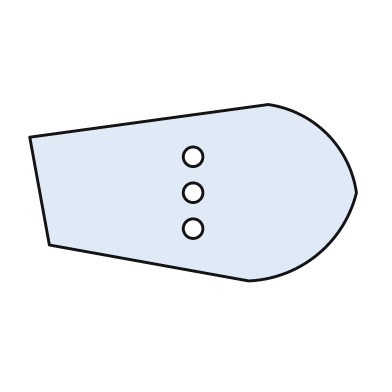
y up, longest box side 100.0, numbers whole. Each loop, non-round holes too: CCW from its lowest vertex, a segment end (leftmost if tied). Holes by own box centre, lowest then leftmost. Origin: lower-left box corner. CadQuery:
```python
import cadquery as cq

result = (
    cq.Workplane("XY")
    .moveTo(67.0, 0.0)
    .threePointArc((88.0, 8.0), (100.0, 27.0))
    .threePointArc((91.0, 45.0), (73.0, 54.0))
    .lineTo(0.0, 44.0)
    .lineTo(6.0, 11.0)
    .close()
    .moveTo(50.0, 16.0)
    .circle(3.0)
    .moveTo(50.0, 27.0)
    .circle(3.0)
    .moveTo(50.0, 38.0)
    .circle(3.0)
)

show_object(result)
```